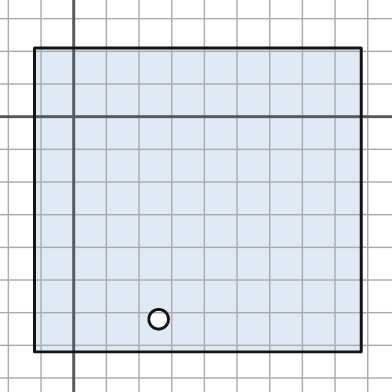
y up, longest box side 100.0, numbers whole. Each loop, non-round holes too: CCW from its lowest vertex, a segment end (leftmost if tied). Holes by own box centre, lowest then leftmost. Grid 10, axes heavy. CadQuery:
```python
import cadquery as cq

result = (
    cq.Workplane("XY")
    .moveTo(-12.0, -72.0)
    .lineTo(88.0, -72.0)
    .lineTo(88.0, 21.0)
    .lineTo(-12.0, 21.0)
    .close()
    .moveTo(26.0, -62.0)
    .circle(3.0)
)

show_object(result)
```